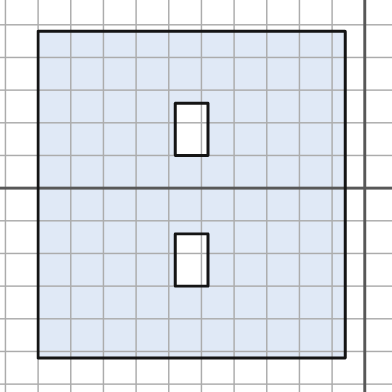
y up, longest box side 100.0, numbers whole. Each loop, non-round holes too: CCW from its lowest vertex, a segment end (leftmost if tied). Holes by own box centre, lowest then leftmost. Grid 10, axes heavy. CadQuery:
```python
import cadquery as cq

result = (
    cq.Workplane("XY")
    .moveTo(-100.0, -52.0)
    .lineTo(-6.0, -52.0)
    .lineTo(-6.0, 48.0)
    .lineTo(-100.0, 48.0)
    .close()
    .moveTo(-58.0, -30.0)
    .lineTo(-48.0, -30.0)
    .lineTo(-48.0, -14.0)
    .lineTo(-58.0, -14.0)
    .close()
    .moveTo(-58.0, 10.0)
    .lineTo(-48.0, 10.0)
    .lineTo(-48.0, 26.0)
    .lineTo(-58.0, 26.0)
    .close()
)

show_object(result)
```